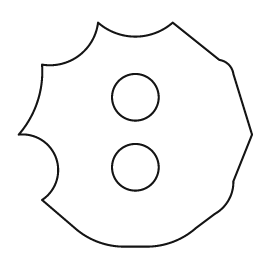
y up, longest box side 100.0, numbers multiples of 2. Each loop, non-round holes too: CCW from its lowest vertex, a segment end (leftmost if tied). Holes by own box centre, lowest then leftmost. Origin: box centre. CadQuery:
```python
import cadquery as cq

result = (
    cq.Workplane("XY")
    .moveTo(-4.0, -48.0)
    .lineTo(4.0, -48.0)
    .threePointArc((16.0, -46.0), (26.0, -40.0))
    .lineTo(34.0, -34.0)
    .threePointArc((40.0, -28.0), (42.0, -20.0))
    .lineTo(50.0, 0.0)
    .lineTo(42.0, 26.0)
    .threePointArc((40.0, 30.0), (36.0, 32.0))
    .lineTo(16.0, 48.0)
    .threePointArc((0.0, 42.0), (-16.0, 48.0))
    .threePointArc((-24.0, 34.0), (-40.0, 30.0))
    .threePointArc((-42.0, 14.0), (-50.0, 0.0))
    .threePointArc((-34.0, -10.0), (-40.0, -28.0))
    .lineTo(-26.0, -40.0)
    .threePointArc((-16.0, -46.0), (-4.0, -48.0))
    .close()
    .moveTo(0.0, -14.0)
    .circle(10.0)
    .moveTo(0.0, 16.0)
    .circle(10.0)
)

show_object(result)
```